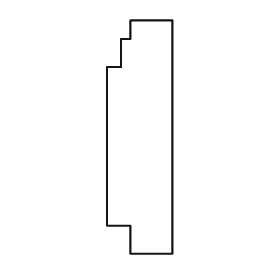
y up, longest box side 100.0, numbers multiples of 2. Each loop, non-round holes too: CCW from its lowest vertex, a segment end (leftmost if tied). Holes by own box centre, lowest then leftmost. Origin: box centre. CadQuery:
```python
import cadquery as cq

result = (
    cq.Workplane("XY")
    .moveTo(-4.0, -50.0)
    .lineTo(14.0, -50.0)
    .lineTo(14.0, 50.0)
    .lineTo(-4.0, 50.0)
    .lineTo(-4.0, 42.0)
    .lineTo(-8.0, 42.0)
    .lineTo(-8.0, 30.0)
    .lineTo(-14.0, 30.0)
    .lineTo(-14.0, -38.0)
    .lineTo(-4.0, -38.0)
    .close()
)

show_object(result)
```